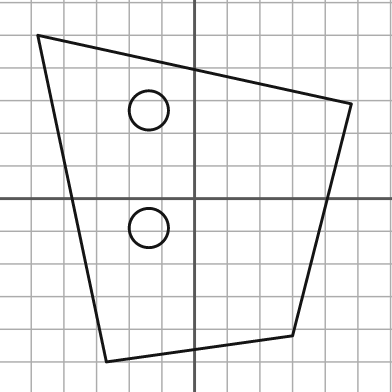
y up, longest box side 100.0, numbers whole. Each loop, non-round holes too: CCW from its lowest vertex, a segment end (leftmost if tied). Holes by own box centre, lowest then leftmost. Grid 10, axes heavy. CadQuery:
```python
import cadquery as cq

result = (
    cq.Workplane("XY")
    .moveTo(-27.0, -50.0)
    .lineTo(30.0, -42.0)
    .lineTo(48.0, 29.0)
    .lineTo(-48.0, 50.0)
    .close()
    .moveTo(-14.0, -9.0)
    .circle(6.0)
    .moveTo(-14.0, 27.0)
    .circle(6.0)
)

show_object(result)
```